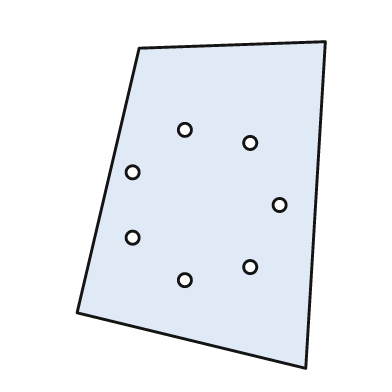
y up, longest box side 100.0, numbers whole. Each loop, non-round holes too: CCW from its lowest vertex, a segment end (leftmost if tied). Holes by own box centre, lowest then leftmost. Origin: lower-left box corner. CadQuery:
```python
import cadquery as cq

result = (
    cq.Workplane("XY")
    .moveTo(70.0, 0.0)
    .lineTo(76.0, 100.0)
    .lineTo(19.0, 98.0)
    .lineTo(0.0, 17.0)
    .close()
    .moveTo(33.0, 27.0)
    .circle(2.0)
    .moveTo(53.0, 31.0)
    .circle(2.0)
    .moveTo(17.0, 40.0)
    .circle(2.0)
    .moveTo(62.0, 50.0)
    .circle(2.0)
    .moveTo(17.0, 60.0)
    .circle(2.0)
    .moveTo(53.0, 69.0)
    .circle(2.0)
    .moveTo(33.0, 73.0)
    .circle(2.0)
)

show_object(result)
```